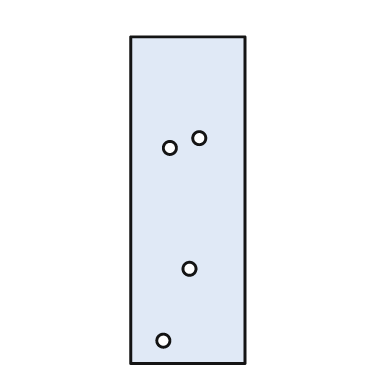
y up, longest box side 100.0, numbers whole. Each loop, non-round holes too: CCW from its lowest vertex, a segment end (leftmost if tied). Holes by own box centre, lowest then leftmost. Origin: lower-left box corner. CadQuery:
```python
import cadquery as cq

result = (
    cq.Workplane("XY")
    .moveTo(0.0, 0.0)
    .lineTo(35.0, 0.0)
    .lineTo(35.0, 100.0)
    .lineTo(0.0, 100.0)
    .close()
    .moveTo(10.0, 7.0)
    .circle(2.0)
    .moveTo(18.0, 29.0)
    .circle(2.0)
    .moveTo(12.0, 66.0)
    .circle(2.0)
    .moveTo(21.0, 69.0)
    .circle(2.0)
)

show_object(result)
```